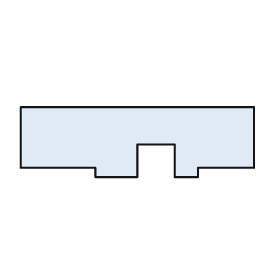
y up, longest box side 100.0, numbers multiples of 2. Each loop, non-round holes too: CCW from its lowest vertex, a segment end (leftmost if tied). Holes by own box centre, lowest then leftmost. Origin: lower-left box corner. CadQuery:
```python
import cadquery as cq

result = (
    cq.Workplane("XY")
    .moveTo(32.0, 0.0)
    .lineTo(50.0, 0.0)
    .lineTo(50.0, 14.0)
    .lineTo(66.0, 14.0)
    .lineTo(66.0, 0.0)
    .lineTo(76.0, 0.0)
    .lineTo(76.0, 4.0)
    .lineTo(100.0, 4.0)
    .lineTo(100.0, 30.0)
    .lineTo(0.0, 30.0)
    .lineTo(0.0, 4.0)
    .lineTo(32.0, 4.0)
    .close()
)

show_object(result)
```